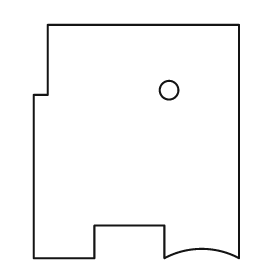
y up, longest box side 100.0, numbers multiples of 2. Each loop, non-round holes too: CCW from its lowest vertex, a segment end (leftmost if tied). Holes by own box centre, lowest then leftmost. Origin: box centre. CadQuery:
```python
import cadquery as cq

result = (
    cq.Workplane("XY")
    .moveTo(-44.0, -50.0)
    .lineTo(-18.0, -50.0)
    .lineTo(-18.0, -36.0)
    .lineTo(12.0, -36.0)
    .lineTo(12.0, -50.0)
    .threePointArc((28.0, -46.0), (44.0, -50.0))
    .lineTo(44.0, 50.0)
    .lineTo(-38.0, 50.0)
    .lineTo(-38.0, 20.0)
    .lineTo(-44.0, 20.0)
    .close()
    .moveTo(14.0, 22.0)
    .circle(4.0)
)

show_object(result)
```